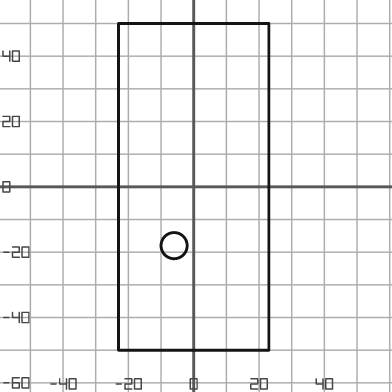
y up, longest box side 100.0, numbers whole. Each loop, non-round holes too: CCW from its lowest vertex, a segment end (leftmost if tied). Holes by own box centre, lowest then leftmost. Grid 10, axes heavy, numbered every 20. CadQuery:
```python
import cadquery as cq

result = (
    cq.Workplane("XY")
    .moveTo(-23.0, -50.0)
    .lineTo(23.0, -50.0)
    .lineTo(23.0, 50.0)
    .lineTo(-23.0, 50.0)
    .close()
    .moveTo(-6.0, -18.0)
    .circle(4.0)
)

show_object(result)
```